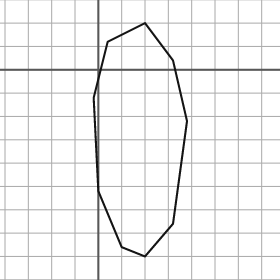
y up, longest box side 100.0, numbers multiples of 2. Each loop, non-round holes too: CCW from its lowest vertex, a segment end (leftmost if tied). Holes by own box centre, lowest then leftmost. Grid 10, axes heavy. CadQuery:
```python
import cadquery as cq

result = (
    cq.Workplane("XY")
    .moveTo(20.0, -80.0)
    .lineTo(32.0, -66.0)
    .lineTo(38.0, -22.0)
    .lineTo(32.0, 4.0)
    .lineTo(20.0, 20.0)
    .lineTo(4.0, 12.0)
    .lineTo(-2.0, -12.0)
    .lineTo(0.0, -52.0)
    .lineTo(10.0, -76.0)
    .close()
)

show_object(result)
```